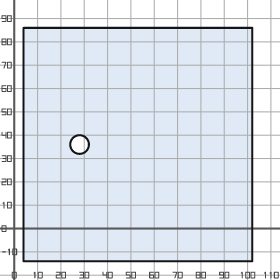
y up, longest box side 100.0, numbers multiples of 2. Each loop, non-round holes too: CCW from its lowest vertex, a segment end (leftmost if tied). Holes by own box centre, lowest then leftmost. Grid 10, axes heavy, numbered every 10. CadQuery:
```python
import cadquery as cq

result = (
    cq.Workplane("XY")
    .moveTo(4.0, -14.0)
    .lineTo(102.0, -14.0)
    .lineTo(102.0, 86.0)
    .lineTo(4.0, 86.0)
    .close()
    .moveTo(28.0, 36.0)
    .circle(4.0)
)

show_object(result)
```